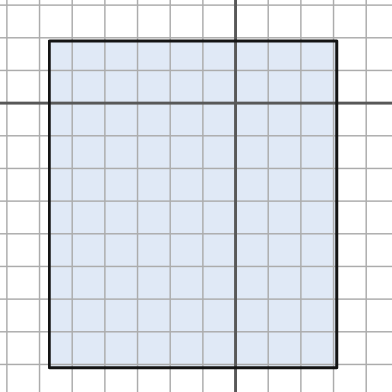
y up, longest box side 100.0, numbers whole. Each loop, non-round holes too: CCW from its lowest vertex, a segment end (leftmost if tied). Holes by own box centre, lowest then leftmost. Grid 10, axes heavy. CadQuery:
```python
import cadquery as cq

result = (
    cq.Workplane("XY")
    .moveTo(-57.0, -81.0)
    .lineTo(31.0, -81.0)
    .lineTo(31.0, 19.0)
    .lineTo(-57.0, 19.0)
    .close()
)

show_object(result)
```